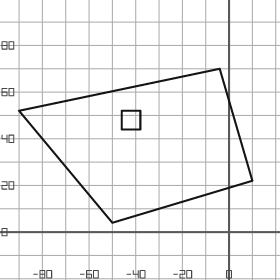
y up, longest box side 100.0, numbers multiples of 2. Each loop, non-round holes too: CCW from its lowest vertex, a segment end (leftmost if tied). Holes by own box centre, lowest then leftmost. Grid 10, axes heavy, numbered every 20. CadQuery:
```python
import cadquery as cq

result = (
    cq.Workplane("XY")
    .moveTo(-50.0, 4.0)
    .lineTo(10.0, 22.0)
    .lineTo(-4.0, 70.0)
    .lineTo(-90.0, 52.0)
    .close()
    .moveTo(-46.0, 44.0)
    .lineTo(-38.0, 44.0)
    .lineTo(-38.0, 52.0)
    .lineTo(-46.0, 52.0)
    .close()
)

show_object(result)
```